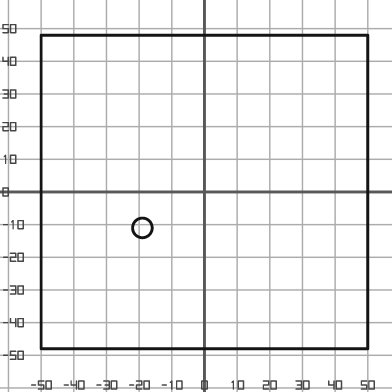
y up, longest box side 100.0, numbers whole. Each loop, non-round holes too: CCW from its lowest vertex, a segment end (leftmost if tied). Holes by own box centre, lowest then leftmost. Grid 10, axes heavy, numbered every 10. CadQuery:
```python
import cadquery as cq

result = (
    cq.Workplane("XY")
    .moveTo(-50.0, -48.0)
    .lineTo(50.0, -48.0)
    .lineTo(50.0, 48.0)
    .lineTo(-50.0, 48.0)
    .close()
    .moveTo(-19.0, -11.0)
    .circle(3.0)
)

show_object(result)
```